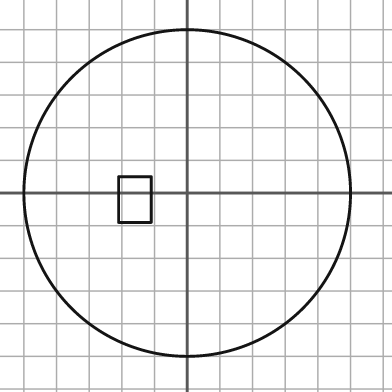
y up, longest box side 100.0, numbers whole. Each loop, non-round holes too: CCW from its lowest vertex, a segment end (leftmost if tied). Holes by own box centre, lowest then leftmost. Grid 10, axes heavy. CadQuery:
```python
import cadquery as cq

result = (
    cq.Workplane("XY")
    .moveTo(0.0, 0.0)
    .circle(50.0)
    .moveTo(-21.0, -9.0)
    .lineTo(-11.0, -9.0)
    .lineTo(-11.0, 5.0)
    .lineTo(-21.0, 5.0)
    .close()
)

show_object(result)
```